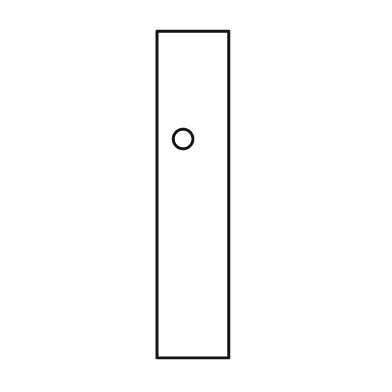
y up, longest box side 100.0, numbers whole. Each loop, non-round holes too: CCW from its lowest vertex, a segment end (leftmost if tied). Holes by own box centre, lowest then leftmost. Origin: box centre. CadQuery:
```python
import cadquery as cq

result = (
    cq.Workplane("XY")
    .moveTo(-11.0, -50.0)
    .lineTo(11.0, -50.0)
    .lineTo(11.0, 50.0)
    .lineTo(-11.0, 50.0)
    .close()
    .moveTo(-3.0, 17.0)
    .circle(3.0)
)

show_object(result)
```